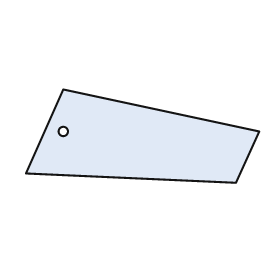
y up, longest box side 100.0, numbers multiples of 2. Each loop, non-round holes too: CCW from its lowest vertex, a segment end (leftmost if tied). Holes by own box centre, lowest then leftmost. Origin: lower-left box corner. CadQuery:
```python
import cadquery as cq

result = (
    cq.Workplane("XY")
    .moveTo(90.0, 0.0)
    .lineTo(100.0, 22.0)
    .lineTo(16.0, 40.0)
    .lineTo(0.0, 4.0)
    .close()
    .moveTo(16.0, 22.0)
    .circle(2.0)
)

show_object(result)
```